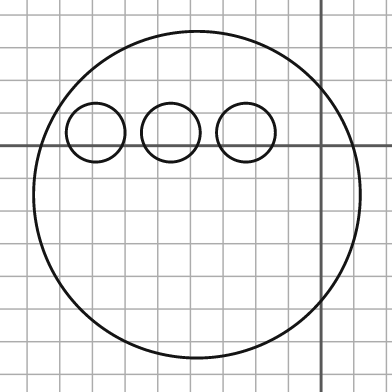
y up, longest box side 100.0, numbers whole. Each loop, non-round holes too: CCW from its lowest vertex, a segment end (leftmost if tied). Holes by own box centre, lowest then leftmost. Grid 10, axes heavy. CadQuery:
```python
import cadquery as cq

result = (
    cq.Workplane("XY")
    .moveTo(-38.0, -15.0)
    .circle(50.0)
    .moveTo(-69.0, 4.0)
    .circle(9.0)
    .moveTo(-46.0, 4.0)
    .circle(9.0)
    .moveTo(-23.0, 4.0)
    .circle(9.0)
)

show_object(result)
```